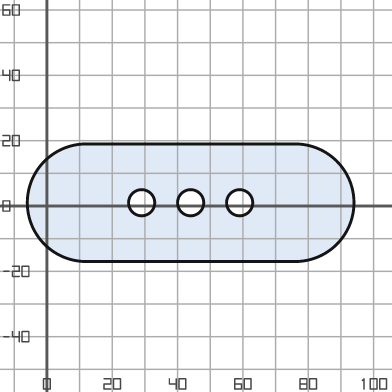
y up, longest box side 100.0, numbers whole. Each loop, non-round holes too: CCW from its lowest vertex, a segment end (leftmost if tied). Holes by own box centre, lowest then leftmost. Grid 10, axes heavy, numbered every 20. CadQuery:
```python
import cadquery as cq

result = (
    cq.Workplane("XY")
    .moveTo(12.0, -17.0)
    .lineTo(76.0, -17.0)
    .threePointArc((94.0, 1.0), (76.0, 19.0))
    .lineTo(12.0, 19.0)
    .threePointArc((-6.0, 1.0), (12.0, -17.0))
    .close()
    .moveTo(29.0, 1.0)
    .circle(4.0)
    .moveTo(44.0, 1.0)
    .circle(4.0)
    .moveTo(59.0, 1.0)
    .circle(4.0)
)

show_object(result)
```